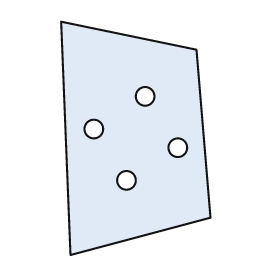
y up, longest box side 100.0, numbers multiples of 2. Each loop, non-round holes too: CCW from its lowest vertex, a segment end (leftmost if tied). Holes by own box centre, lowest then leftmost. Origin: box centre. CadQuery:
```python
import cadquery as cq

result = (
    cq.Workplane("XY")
    .moveTo(-28.0, -50.0)
    .lineTo(32.0, -34.0)
    .lineTo(26.0, 38.0)
    .lineTo(-32.0, 50.0)
    .close()
    .moveTo(-4.0, -18.0)
    .circle(4.0)
    .moveTo(18.0, -4.0)
    .circle(4.0)
    .moveTo(-18.0, 4.0)
    .circle(4.0)
    .moveTo(4.0, 18.0)
    .circle(4.0)
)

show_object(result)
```